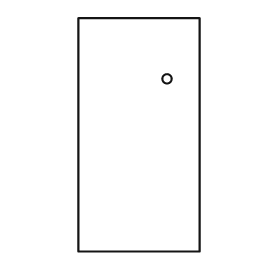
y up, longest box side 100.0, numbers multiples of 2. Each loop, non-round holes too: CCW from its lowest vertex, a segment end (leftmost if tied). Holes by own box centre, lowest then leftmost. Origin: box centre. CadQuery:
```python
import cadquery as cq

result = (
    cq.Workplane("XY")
    .moveTo(-26.0, -50.0)
    .lineTo(26.0, -50.0)
    .lineTo(26.0, 50.0)
    .lineTo(-26.0, 50.0)
    .close()
    .moveTo(12.0, 24.0)
    .circle(2.0)
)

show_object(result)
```